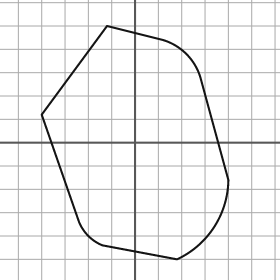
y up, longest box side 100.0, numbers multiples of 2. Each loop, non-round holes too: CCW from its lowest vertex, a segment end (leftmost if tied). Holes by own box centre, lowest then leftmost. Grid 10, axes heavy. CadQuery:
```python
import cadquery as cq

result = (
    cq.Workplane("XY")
    .moveTo(18.0, -50.0)
    .threePointArc((34.0, -36.0), (40.0, -16.0))
    .lineTo(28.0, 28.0)
    .threePointArc((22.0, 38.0), (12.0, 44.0))
    .lineTo(-12.0, 50.0)
    .lineTo(-40.0, 12.0)
    .lineTo(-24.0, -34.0)
    .threePointArc((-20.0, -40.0), (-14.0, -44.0))
    .close()
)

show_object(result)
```